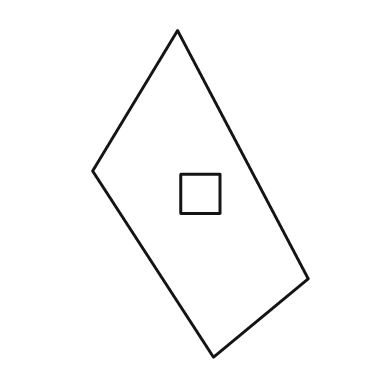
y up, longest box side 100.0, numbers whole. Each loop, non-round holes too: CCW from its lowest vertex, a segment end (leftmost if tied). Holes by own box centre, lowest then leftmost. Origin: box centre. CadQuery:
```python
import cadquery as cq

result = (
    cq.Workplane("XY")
    .moveTo(4.0, -50.0)
    .lineTo(33.0, -26.0)
    .lineTo(-7.0, 50.0)
    .lineTo(-33.0, 7.0)
    .close()
    .moveTo(-6.0, -6.0)
    .lineTo(6.0, -6.0)
    .lineTo(6.0, 6.0)
    .lineTo(-6.0, 6.0)
    .close()
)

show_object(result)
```